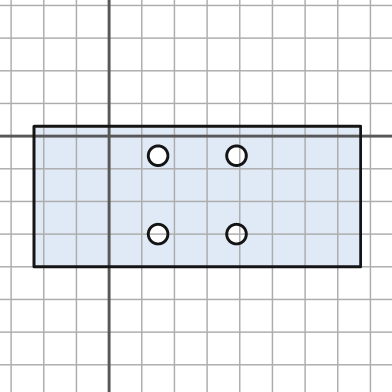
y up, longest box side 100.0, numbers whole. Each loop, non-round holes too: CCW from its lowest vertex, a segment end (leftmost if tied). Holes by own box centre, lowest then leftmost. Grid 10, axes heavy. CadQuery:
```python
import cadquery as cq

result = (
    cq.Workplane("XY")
    .moveTo(-23.0, -40.0)
    .lineTo(77.0, -40.0)
    .lineTo(77.0, 3.0)
    .lineTo(-23.0, 3.0)
    .close()
    .moveTo(15.0, -30.0)
    .circle(3.0)
    .moveTo(39.0, -30.0)
    .circle(3.0)
    .moveTo(15.0, -6.0)
    .circle(3.0)
    .moveTo(39.0, -6.0)
    .circle(3.0)
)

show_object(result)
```